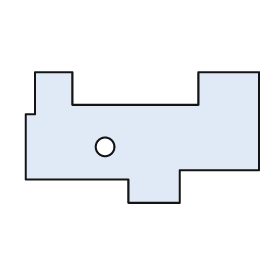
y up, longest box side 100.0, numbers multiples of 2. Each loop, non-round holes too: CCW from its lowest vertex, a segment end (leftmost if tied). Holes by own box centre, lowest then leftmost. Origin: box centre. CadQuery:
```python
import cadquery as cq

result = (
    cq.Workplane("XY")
    .moveTo(-6.0, -28.0)
    .lineTo(16.0, -28.0)
    .lineTo(16.0, -14.0)
    .lineTo(50.0, -14.0)
    .lineTo(50.0, 28.0)
    .lineTo(24.0, 28.0)
    .lineTo(24.0, 14.0)
    .lineTo(-30.0, 14.0)
    .lineTo(-30.0, 28.0)
    .lineTo(-46.0, 28.0)
    .lineTo(-46.0, 10.0)
    .lineTo(-50.0, 10.0)
    .lineTo(-50.0, -18.0)
    .lineTo(-6.0, -18.0)
    .close()
    .moveTo(-16.0, -4.0)
    .circle(4.0)
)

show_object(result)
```